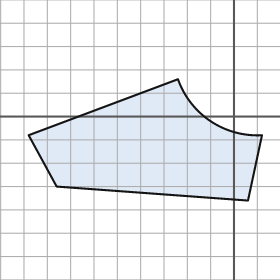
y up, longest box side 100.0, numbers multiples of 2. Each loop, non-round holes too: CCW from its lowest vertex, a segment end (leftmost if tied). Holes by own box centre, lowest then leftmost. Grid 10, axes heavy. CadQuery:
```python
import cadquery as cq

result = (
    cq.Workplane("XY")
    .moveTo(6.0, -36.0)
    .lineTo(12.0, -8.0)
    .threePointArc((-10.0, -2.0), (-24.0, 16.0))
    .lineTo(-88.0, -8.0)
    .lineTo(-76.0, -30.0)
    .close()
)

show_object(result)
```